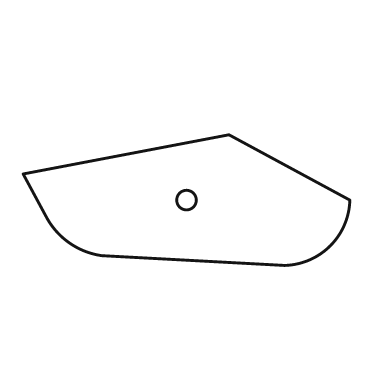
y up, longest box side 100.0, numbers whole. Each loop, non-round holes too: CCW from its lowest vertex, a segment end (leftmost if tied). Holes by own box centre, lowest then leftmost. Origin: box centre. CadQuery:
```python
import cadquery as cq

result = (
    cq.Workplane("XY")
    .moveTo(30.0, -20.0)
    .threePointArc((44.0, -14.0), (50.0, 0.0))
    .lineTo(13.0, 20.0)
    .lineTo(-50.0, 8.0)
    .lineTo(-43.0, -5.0)
    .threePointArc((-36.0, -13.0), (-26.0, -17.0))
    .close()
    .moveTo(0.0, 0.0)
    .circle(3.0)
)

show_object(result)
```